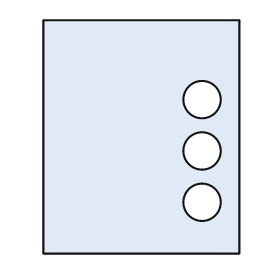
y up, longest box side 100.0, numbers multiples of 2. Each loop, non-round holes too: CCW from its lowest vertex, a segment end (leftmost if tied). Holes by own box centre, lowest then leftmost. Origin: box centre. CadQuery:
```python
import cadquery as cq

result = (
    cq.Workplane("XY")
    .moveTo(-42.0, -50.0)
    .lineTo(42.0, -50.0)
    .lineTo(42.0, 50.0)
    .lineTo(-42.0, 50.0)
    .close()
    .moveTo(26.0, -28.0)
    .circle(8.0)
    .moveTo(26.0, -6.0)
    .circle(8.0)
    .moveTo(26.0, 16.0)
    .circle(8.0)
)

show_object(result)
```